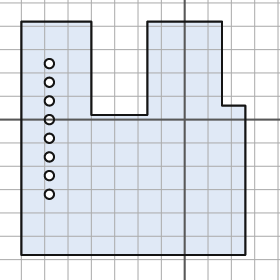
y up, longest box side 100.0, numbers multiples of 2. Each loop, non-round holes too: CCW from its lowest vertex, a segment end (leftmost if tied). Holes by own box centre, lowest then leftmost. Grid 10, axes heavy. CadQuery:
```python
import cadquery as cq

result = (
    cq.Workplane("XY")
    .moveTo(-70.0, -58.0)
    .lineTo(26.0, -58.0)
    .lineTo(26.0, 6.0)
    .lineTo(16.0, 6.0)
    .lineTo(16.0, 42.0)
    .lineTo(-16.0, 42.0)
    .lineTo(-16.0, 2.0)
    .lineTo(-40.0, 2.0)
    .lineTo(-40.0, 42.0)
    .lineTo(-70.0, 42.0)
    .close()
    .moveTo(-58.0, -32.0)
    .circle(2.0)
    .moveTo(-58.0, -24.0)
    .circle(2.0)
    .moveTo(-58.0, -16.0)
    .circle(2.0)
    .moveTo(-58.0, -8.0)
    .circle(2.0)
    .moveTo(-58.0, 0.0)
    .circle(2.0)
    .moveTo(-58.0, 8.0)
    .circle(2.0)
    .moveTo(-58.0, 16.0)
    .circle(2.0)
    .moveTo(-58.0, 24.0)
    .circle(2.0)
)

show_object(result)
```